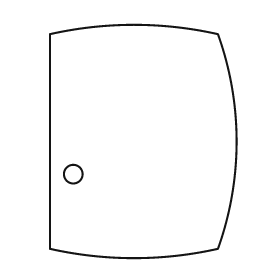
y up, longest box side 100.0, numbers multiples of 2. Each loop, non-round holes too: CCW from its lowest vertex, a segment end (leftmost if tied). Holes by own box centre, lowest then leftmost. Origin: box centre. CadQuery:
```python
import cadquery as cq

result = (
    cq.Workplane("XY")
    .moveTo(-40.0, -46.0)
    .threePointArc((-4.0, -50.0), (32.0, -46.0))
    .threePointArc((40.0, 0.0), (32.0, 46.0))
    .threePointArc((-4.0, 50.0), (-40.0, 46.0))
    .close()
    .moveTo(-30.0, -14.0)
    .circle(4.0)
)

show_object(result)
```